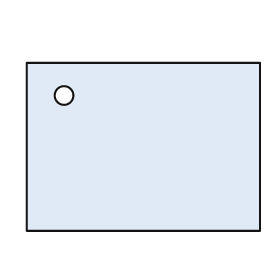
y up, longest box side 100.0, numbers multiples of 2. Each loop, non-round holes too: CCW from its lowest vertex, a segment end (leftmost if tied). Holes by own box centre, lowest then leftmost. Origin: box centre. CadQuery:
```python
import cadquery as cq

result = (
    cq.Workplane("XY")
    .moveTo(-50.0, -36.0)
    .lineTo(50.0, -36.0)
    .lineTo(50.0, 36.0)
    .lineTo(-50.0, 36.0)
    .close()
    .moveTo(-34.0, 22.0)
    .circle(4.0)
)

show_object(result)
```